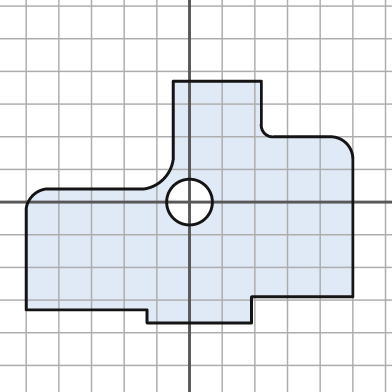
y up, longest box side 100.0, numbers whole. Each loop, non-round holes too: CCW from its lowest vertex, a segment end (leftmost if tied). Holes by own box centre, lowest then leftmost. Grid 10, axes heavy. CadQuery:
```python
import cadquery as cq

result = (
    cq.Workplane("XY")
    .moveTo(-13.0, -37.0)
    .lineTo(19.0, -37.0)
    .lineTo(19.0, -29.0)
    .lineTo(50.0, -29.0)
    .lineTo(50.0, 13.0)
    .threePointArc((48.0, 18.0), (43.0, 20.0))
    .lineTo(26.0, 20.0)
    .threePointArc((23.0, 21.0), (22.0, 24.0))
    .lineTo(22.0, 37.0)
    .lineTo(-5.0, 37.0)
    .lineTo(-5.0, 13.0)
    .threePointArc((-8.0, 7.0), (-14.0, 4.0))
    .lineTo(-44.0, 4.0)
    .threePointArc((-48.0, 2.0), (-50.0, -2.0))
    .lineTo(-50.0, -33.0)
    .lineTo(-13.0, -33.0)
    .close()
    .moveTo(0.0, 0.0)
    .circle(7.0)
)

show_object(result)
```